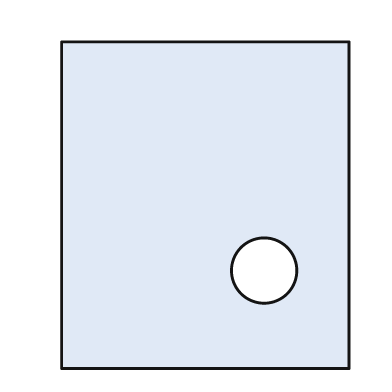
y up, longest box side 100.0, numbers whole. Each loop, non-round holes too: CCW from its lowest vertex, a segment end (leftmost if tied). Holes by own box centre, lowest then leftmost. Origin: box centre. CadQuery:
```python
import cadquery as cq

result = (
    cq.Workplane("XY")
    .moveTo(-44.0, -50.0)
    .lineTo(44.0, -50.0)
    .lineTo(44.0, 50.0)
    .lineTo(-44.0, 50.0)
    .close()
    .moveTo(18.0, -20.0)
    .circle(10.0)
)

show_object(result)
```